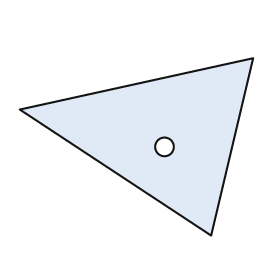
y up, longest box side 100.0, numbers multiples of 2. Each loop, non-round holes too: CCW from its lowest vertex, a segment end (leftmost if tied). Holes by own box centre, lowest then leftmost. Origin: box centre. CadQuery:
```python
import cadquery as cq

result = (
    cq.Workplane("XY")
    .moveTo(32.0, -38.0)
    .lineTo(50.0, 38.0)
    .lineTo(-50.0, 16.0)
    .close()
    .moveTo(12.0, 0.0)
    .circle(4.0)
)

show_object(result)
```